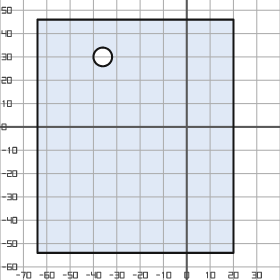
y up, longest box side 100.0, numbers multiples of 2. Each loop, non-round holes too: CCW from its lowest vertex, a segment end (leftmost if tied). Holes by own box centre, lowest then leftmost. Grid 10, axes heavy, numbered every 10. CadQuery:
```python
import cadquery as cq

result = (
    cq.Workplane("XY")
    .moveTo(-64.0, -54.0)
    .lineTo(20.0, -54.0)
    .lineTo(20.0, 46.0)
    .lineTo(-64.0, 46.0)
    .close()
    .moveTo(-36.0, 30.0)
    .circle(4.0)
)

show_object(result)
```